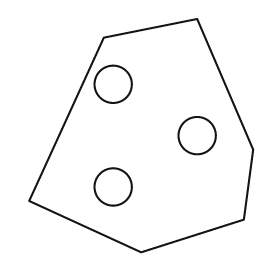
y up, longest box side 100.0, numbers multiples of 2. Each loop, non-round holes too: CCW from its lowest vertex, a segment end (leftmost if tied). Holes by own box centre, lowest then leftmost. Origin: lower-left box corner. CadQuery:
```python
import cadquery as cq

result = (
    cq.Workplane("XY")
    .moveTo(48.0, 0.0)
    .lineTo(92.0, 14.0)
    .lineTo(96.0, 44.0)
    .lineTo(72.0, 100.0)
    .lineTo(32.0, 92.0)
    .lineTo(0.0, 22.0)
    .close()
    .moveTo(36.0, 28.0)
    .circle(8.0)
    .moveTo(72.0, 50.0)
    .circle(8.0)
    .moveTo(36.0, 72.0)
    .circle(8.0)
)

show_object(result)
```